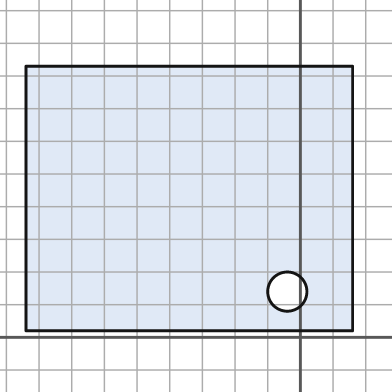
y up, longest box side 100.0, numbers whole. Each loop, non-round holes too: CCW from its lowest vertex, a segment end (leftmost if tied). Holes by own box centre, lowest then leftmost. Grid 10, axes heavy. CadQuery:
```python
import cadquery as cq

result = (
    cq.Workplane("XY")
    .moveTo(-84.0, 2.0)
    .lineTo(16.0, 2.0)
    .lineTo(16.0, 83.0)
    .lineTo(-84.0, 83.0)
    .close()
    .moveTo(-4.0, 14.0)
    .circle(6.0)
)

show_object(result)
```